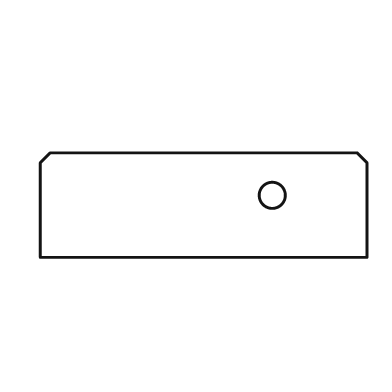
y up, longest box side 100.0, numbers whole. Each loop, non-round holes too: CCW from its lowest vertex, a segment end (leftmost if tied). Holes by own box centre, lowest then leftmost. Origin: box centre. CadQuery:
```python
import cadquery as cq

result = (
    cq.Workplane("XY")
    .moveTo(-50.0, -16.0)
    .lineTo(50.0, -16.0)
    .lineTo(50.0, 13.0)
    .lineTo(47.0, 16.0)
    .lineTo(-47.0, 16.0)
    .lineTo(-50.0, 13.0)
    .close()
    .moveTo(21.0, 3.0)
    .circle(4.0)
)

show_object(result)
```